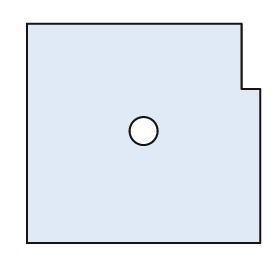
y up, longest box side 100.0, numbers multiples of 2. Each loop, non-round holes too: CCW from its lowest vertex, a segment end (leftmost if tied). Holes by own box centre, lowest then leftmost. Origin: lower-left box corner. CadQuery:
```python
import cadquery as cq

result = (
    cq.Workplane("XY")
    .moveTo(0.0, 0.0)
    .lineTo(100.0, 0.0)
    .lineTo(100.0, 66.0)
    .lineTo(92.0, 66.0)
    .lineTo(92.0, 94.0)
    .lineTo(0.0, 94.0)
    .close()
    .moveTo(50.0, 48.0)
    .circle(6.0)
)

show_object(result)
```